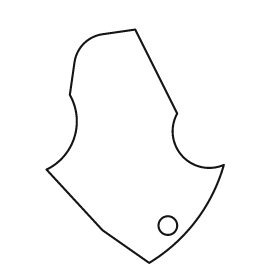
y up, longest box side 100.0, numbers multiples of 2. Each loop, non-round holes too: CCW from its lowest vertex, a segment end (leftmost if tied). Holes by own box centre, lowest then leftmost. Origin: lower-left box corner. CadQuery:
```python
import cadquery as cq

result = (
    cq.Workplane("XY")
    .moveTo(44.0, 0.0)
    .threePointArc((64.0, 18.0), (76.0, 42.0))
    .threePointArc((58.0, 46.0), (56.0, 64.0))
    .lineTo(38.0, 100.0)
    .lineTo(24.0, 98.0)
    .threePointArc((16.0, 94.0), (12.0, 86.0))
    .lineTo(10.0, 72.0)
    .threePointArc((12.0, 54.0), (0.0, 40.0))
    .lineTo(24.0, 14.0)
    .close()
    .moveTo(52.0, 16.0)
    .circle(4.0)
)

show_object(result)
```